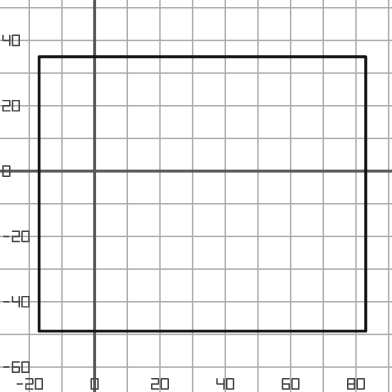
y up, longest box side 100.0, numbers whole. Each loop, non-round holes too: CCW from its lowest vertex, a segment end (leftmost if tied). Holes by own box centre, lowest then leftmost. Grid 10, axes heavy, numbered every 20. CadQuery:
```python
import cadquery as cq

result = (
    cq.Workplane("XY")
    .moveTo(-17.0, -49.0)
    .lineTo(83.0, -49.0)
    .lineTo(83.0, 35.0)
    .lineTo(-17.0, 35.0)
    .close()
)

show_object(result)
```